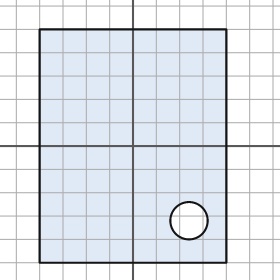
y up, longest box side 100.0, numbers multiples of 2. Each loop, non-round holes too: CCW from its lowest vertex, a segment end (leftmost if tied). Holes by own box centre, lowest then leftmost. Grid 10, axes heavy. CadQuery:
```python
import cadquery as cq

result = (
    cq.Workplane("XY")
    .moveTo(-40.0, -50.0)
    .lineTo(40.0, -50.0)
    .lineTo(40.0, 50.0)
    .lineTo(-40.0, 50.0)
    .close()
    .moveTo(24.0, -32.0)
    .circle(8.0)
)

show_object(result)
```